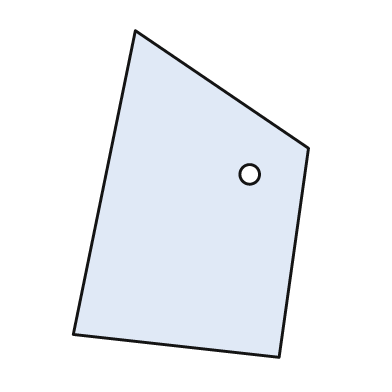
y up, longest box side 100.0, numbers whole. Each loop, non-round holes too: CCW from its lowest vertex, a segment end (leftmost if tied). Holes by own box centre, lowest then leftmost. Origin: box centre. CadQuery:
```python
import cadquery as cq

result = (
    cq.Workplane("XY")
    .moveTo(27.0, -50.0)
    .lineTo(36.0, 14.0)
    .lineTo(-17.0, 50.0)
    .lineTo(-36.0, -43.0)
    .close()
    .moveTo(18.0, 6.0)
    .circle(3.0)
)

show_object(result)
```